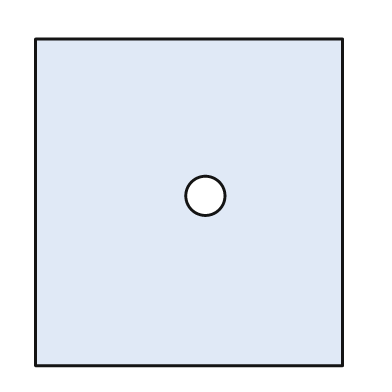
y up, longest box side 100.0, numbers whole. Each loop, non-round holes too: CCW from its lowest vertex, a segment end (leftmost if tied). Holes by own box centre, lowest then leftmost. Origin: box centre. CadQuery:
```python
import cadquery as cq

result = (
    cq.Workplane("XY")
    .moveTo(-47.0, -50.0)
    .lineTo(47.0, -50.0)
    .lineTo(47.0, 50.0)
    .lineTo(-47.0, 50.0)
    .close()
    .moveTo(5.0, 2.0)
    .circle(6.0)
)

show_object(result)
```